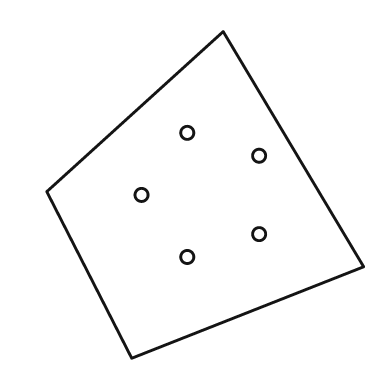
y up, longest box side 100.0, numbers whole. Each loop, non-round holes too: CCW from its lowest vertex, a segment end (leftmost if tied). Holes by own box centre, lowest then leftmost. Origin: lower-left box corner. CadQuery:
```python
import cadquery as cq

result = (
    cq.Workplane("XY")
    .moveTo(26.0, 0.0)
    .lineTo(97.0, 28.0)
    .lineTo(54.0, 100.0)
    .lineTo(0.0, 51.0)
    .close()
    .moveTo(43.0, 31.0)
    .circle(2.0)
    .moveTo(65.0, 38.0)
    .circle(2.0)
    .moveTo(29.0, 50.0)
    .circle(2.0)
    .moveTo(65.0, 62.0)
    .circle(2.0)
    .moveTo(43.0, 69.0)
    .circle(2.0)
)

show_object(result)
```